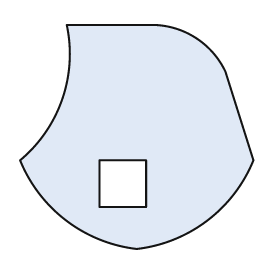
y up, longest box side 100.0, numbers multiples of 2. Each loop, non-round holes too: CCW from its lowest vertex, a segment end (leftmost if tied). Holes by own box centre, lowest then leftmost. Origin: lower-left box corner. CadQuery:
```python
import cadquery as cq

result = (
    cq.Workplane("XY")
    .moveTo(50.0, 0.0)
    .threePointArc((80.0, 12.0), (100.0, 38.0))
    .lineTo(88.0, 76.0)
    .threePointArc((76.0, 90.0), (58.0, 96.0))
    .lineTo(20.0, 96.0)
    .threePointArc((18.0, 64.0), (0.0, 38.0))
    .threePointArc((20.0, 12.0), (50.0, 0.0))
    .close()
    .moveTo(34.0, 18.0)
    .lineTo(54.0, 18.0)
    .lineTo(54.0, 38.0)
    .lineTo(34.0, 38.0)
    .close()
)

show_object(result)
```